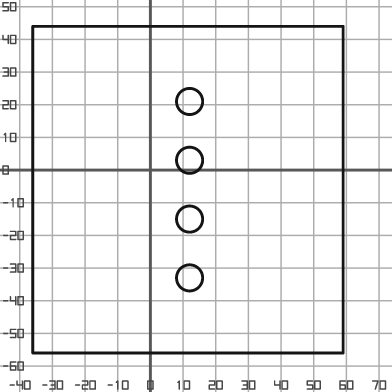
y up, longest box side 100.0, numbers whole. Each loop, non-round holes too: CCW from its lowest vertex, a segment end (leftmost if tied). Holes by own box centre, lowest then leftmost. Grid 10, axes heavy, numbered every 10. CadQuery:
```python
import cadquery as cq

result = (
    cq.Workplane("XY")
    .moveTo(-36.0, -56.0)
    .lineTo(59.0, -56.0)
    .lineTo(59.0, 44.0)
    .lineTo(-36.0, 44.0)
    .close()
    .moveTo(12.0, -33.0)
    .circle(4.0)
    .moveTo(12.0, -15.0)
    .circle(4.0)
    .moveTo(12.0, 3.0)
    .circle(4.0)
    .moveTo(12.0, 21.0)
    .circle(4.0)
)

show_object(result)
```